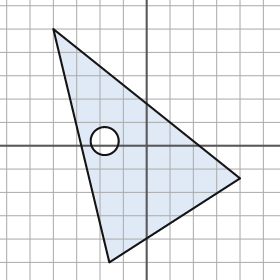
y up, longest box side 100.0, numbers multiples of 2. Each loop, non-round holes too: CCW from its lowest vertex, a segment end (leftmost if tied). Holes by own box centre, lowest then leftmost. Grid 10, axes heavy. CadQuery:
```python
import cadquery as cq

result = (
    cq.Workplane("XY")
    .moveTo(-16.0, -50.0)
    .lineTo(40.0, -14.0)
    .lineTo(-40.0, 50.0)
    .close()
    .moveTo(-18.0, 2.0)
    .circle(6.0)
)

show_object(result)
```